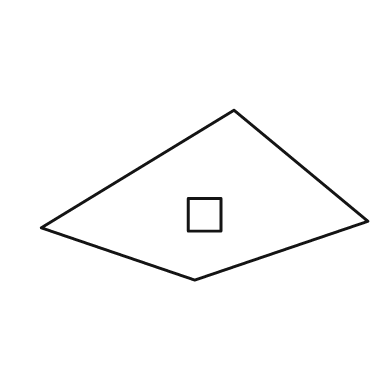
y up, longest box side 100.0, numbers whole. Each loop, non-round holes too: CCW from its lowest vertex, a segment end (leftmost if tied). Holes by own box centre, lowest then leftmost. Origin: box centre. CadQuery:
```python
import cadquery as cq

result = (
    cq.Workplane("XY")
    .moveTo(-3.0, -26.0)
    .lineTo(50.0, -8.0)
    .lineTo(9.0, 26.0)
    .lineTo(-50.0, -10.0)
    .close()
    .moveTo(-5.0, -11.0)
    .lineTo(5.0, -11.0)
    .lineTo(5.0, -1.0)
    .lineTo(-5.0, -1.0)
    .close()
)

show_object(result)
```